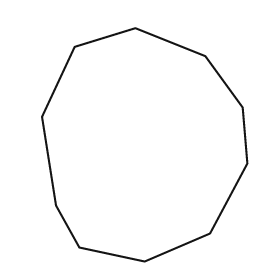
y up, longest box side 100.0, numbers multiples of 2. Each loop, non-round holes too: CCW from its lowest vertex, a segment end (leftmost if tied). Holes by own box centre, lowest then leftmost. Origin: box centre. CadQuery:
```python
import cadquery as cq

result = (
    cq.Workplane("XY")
    .moveTo(0.0, -50.0)
    .lineTo(28.0, -38.0)
    .lineTo(44.0, -8.0)
    .lineTo(42.0, 16.0)
    .lineTo(26.0, 38.0)
    .lineTo(-4.0, 50.0)
    .lineTo(-30.0, 42.0)
    .lineTo(-44.0, 12.0)
    .lineTo(-38.0, -26.0)
    .lineTo(-28.0, -44.0)
    .close()
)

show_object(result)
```